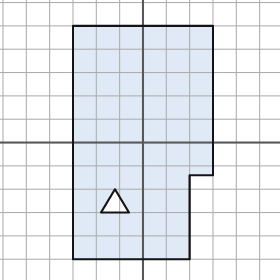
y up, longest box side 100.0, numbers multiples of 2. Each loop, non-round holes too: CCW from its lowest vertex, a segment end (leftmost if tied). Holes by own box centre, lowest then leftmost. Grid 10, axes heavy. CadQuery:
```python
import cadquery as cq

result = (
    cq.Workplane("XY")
    .moveTo(-30.0, -50.0)
    .lineTo(20.0, -50.0)
    .lineTo(20.0, -14.0)
    .lineTo(30.0, -14.0)
    .lineTo(30.0, 50.0)
    .lineTo(-30.0, 50.0)
    .close()
    .moveTo(-18.0, -30.0)
    .lineTo(-6.0, -30.0)
    .lineTo(-12.0, -20.0)
    .close()
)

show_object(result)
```